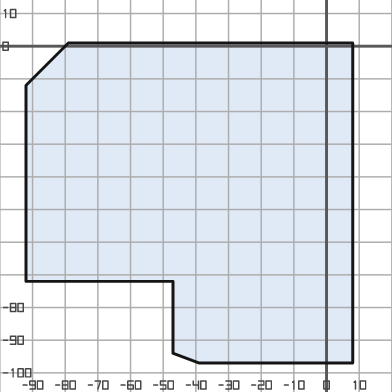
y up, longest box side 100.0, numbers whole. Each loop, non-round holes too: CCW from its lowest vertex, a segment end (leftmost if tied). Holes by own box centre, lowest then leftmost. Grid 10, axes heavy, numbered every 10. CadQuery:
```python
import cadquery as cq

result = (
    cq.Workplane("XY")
    .moveTo(-39.0, -97.0)
    .lineTo(8.0, -97.0)
    .lineTo(8.0, 1.0)
    .lineTo(-79.0, 1.0)
    .lineTo(-92.0, -12.0)
    .lineTo(-92.0, -72.0)
    .lineTo(-47.0, -72.0)
    .lineTo(-47.0, -94.0)
    .close()
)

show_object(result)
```